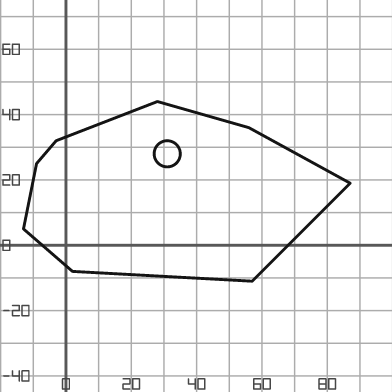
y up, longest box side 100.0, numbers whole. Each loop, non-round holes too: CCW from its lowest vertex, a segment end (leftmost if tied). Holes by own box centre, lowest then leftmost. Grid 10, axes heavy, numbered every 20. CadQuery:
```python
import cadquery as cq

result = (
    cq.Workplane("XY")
    .moveTo(57.0, -11.0)
    .lineTo(87.0, 19.0)
    .lineTo(56.0, 36.0)
    .lineTo(28.0, 44.0)
    .lineTo(-3.0, 32.0)
    .lineTo(-9.0, 25.0)
    .lineTo(-13.0, 5.0)
    .lineTo(2.0, -8.0)
    .close()
    .moveTo(31.0, 28.0)
    .circle(4.0)
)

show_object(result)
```